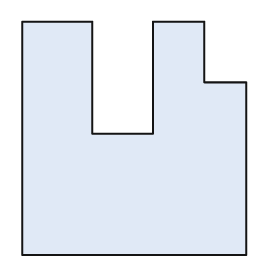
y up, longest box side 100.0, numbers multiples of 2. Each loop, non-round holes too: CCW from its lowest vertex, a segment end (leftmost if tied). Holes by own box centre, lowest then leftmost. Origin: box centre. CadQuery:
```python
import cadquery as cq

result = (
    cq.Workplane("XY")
    .moveTo(-48.0, -50.0)
    .lineTo(48.0, -50.0)
    .lineTo(48.0, 24.0)
    .lineTo(30.0, 24.0)
    .lineTo(30.0, 50.0)
    .lineTo(8.0, 50.0)
    .lineTo(8.0, 2.0)
    .lineTo(-18.0, 2.0)
    .lineTo(-18.0, 50.0)
    .lineTo(-48.0, 50.0)
    .close()
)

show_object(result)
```